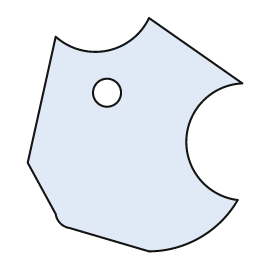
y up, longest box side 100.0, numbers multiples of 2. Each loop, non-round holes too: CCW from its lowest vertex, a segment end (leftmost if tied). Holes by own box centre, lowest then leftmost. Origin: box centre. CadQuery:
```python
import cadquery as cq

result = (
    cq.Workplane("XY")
    .moveTo(6.0, -50.0)
    .threePointArc((28.0, -44.0), (44.0, -28.0))
    .threePointArc((22.0, -2.0), (46.0, 22.0))
    .lineTo(6.0, 50.0)
    .threePointArc((-12.0, 36.0), (-34.0, 42.0))
    .lineTo(-46.0, -12.0)
    .lineTo(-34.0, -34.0)
    .threePointArc((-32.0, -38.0), (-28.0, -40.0))
    .close()
    .moveTo(-12.0, 18.0)
    .circle(6.0)
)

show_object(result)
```